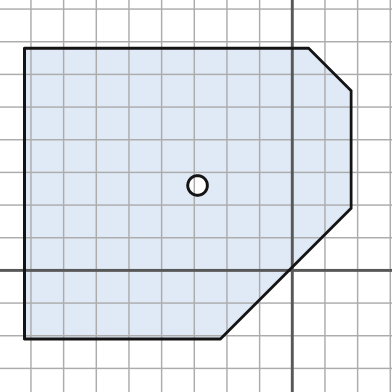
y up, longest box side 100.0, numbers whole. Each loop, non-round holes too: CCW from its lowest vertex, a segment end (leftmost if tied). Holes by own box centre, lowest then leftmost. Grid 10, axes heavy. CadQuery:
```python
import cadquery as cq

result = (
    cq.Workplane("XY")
    .moveTo(-82.0, -21.0)
    .lineTo(-22.0, -21.0)
    .lineTo(18.0, 19.0)
    .lineTo(18.0, 55.0)
    .lineTo(5.0, 68.0)
    .lineTo(-82.0, 68.0)
    .close()
    .moveTo(-29.0, 26.0)
    .circle(3.0)
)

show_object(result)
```